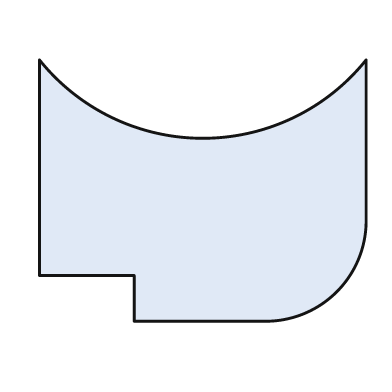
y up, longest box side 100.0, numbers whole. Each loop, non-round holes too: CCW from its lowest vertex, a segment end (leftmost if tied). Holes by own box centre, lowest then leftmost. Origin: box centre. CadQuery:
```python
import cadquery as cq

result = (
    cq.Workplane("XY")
    .moveTo(-21.0, -40.0)
    .lineTo(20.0, -40.0)
    .threePointArc((41.0, -31.0), (50.0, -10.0))
    .lineTo(50.0, 40.0)
    .threePointArc((0.0, 16.0), (-50.0, 40.0))
    .lineTo(-50.0, -26.0)
    .lineTo(-21.0, -26.0)
    .close()
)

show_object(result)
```